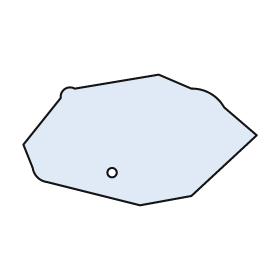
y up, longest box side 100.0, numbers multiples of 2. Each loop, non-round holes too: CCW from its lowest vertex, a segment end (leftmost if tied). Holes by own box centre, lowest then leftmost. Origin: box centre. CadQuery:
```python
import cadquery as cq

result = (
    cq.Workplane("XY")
    .moveTo(0.0, -28.0)
    .lineTo(22.0, -24.0)
    .lineTo(50.0, 2.0)
    .lineTo(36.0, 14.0)
    .threePointArc((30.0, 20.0), (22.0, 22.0))
    .lineTo(8.0, 28.0)
    .lineTo(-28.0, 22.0)
    .threePointArc((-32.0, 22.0), (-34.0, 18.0))
    .lineTo(-50.0, -2.0)
    .lineTo(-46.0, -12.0)
    .threePointArc((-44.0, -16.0), (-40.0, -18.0))
    .close()
    .moveTo(-12.0, -14.0)
    .circle(2.0)
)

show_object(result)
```